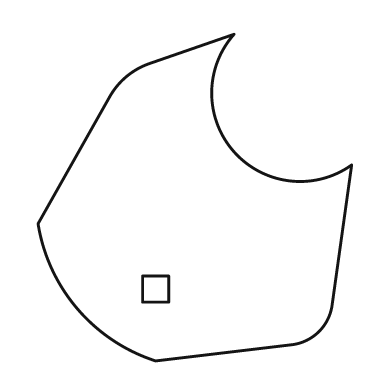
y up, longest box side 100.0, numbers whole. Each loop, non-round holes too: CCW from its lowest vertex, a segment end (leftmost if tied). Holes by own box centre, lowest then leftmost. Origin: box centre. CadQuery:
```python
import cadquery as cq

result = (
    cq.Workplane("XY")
    .moveTo(-12.0, -50.0)
    .lineTo(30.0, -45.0)
    .threePointArc((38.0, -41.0), (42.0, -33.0))
    .lineTo(48.0, 10.0)
    .threePointArc((12.0, 14.0), (12.0, 50.0))
    .lineTo(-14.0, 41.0)
    .threePointArc((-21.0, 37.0), (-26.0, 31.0))
    .lineTo(-48.0, -8.0)
    .threePointArc((-36.0, -34.0), (-12.0, -50.0))
    .close()
    .moveTo(-16.0, -32.0)
    .lineTo(-8.0, -32.0)
    .lineTo(-8.0, -24.0)
    .lineTo(-16.0, -24.0)
    .close()
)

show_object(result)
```